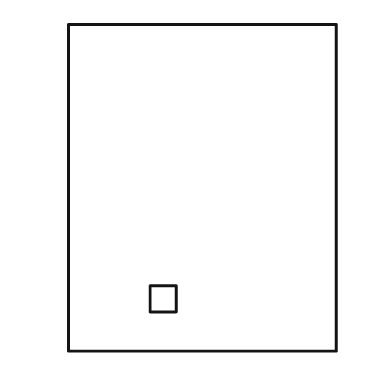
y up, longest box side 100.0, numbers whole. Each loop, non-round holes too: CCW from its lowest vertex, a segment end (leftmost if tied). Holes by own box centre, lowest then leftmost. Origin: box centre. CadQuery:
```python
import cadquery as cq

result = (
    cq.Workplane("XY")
    .moveTo(-41.0, -50.0)
    .lineTo(41.0, -50.0)
    .lineTo(41.0, 50.0)
    .lineTo(-41.0, 50.0)
    .close()
    .moveTo(-16.0, -38.0)
    .lineTo(-8.0, -38.0)
    .lineTo(-8.0, -30.0)
    .lineTo(-16.0, -30.0)
    .close()
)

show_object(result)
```